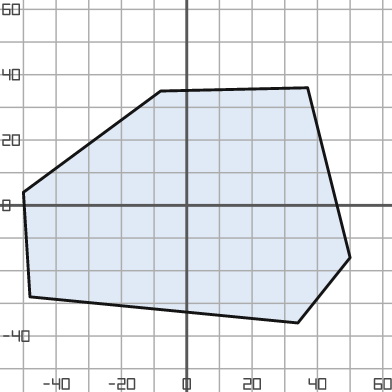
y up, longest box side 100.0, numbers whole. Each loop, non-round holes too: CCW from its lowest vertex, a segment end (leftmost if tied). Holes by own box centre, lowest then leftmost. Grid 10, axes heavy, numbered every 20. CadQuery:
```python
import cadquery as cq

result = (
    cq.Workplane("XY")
    .moveTo(34.0, -36.0)
    .lineTo(50.0, -16.0)
    .lineTo(37.0, 36.0)
    .lineTo(-8.0, 35.0)
    .lineTo(-50.0, 4.0)
    .lineTo(-48.0, -28.0)
    .close()
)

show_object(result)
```